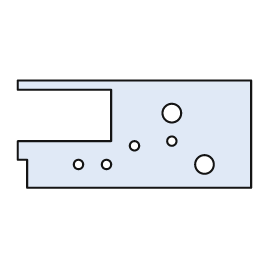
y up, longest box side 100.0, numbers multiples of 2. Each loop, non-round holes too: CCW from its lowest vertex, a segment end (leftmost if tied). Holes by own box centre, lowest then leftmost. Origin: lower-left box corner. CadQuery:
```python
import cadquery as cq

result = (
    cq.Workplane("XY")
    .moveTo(4.0, 0.0)
    .lineTo(100.0, 0.0)
    .lineTo(100.0, 46.0)
    .lineTo(0.0, 46.0)
    .lineTo(0.0, 42.0)
    .lineTo(40.0, 42.0)
    .lineTo(40.0, 20.0)
    .lineTo(0.0, 20.0)
    .lineTo(0.0, 12.0)
    .lineTo(4.0, 12.0)
    .close()
    .moveTo(26.0, 10.0)
    .circle(2.0)
    .moveTo(38.0, 10.0)
    .circle(2.0)
    .moveTo(80.0, 10.0)
    .circle(4.0)
    .moveTo(50.0, 18.0)
    .circle(2.0)
    .moveTo(66.0, 20.0)
    .circle(2.0)
    .moveTo(66.0, 32.0)
    .circle(4.0)
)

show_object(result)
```